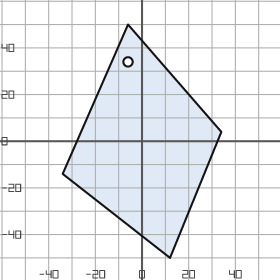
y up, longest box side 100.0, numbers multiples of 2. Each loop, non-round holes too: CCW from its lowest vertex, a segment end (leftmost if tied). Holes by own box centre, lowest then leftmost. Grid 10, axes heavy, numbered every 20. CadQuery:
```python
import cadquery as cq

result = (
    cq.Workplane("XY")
    .moveTo(12.0, -50.0)
    .lineTo(34.0, 4.0)
    .lineTo(-6.0, 50.0)
    .lineTo(-34.0, -14.0)
    .close()
    .moveTo(-6.0, 34.0)
    .circle(2.0)
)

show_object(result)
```